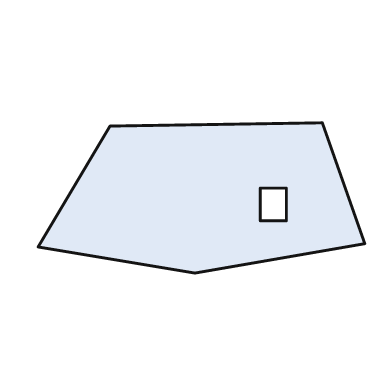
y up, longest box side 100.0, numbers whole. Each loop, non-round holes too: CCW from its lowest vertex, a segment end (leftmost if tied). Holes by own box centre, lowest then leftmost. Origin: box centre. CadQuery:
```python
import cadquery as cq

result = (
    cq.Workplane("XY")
    .moveTo(-2.0, -23.0)
    .lineTo(50.0, -14.0)
    .lineTo(37.0, 23.0)
    .lineTo(-28.0, 22.0)
    .lineTo(-50.0, -15.0)
    .close()
    .moveTo(18.0, -7.0)
    .lineTo(26.0, -7.0)
    .lineTo(26.0, 3.0)
    .lineTo(18.0, 3.0)
    .close()
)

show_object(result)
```